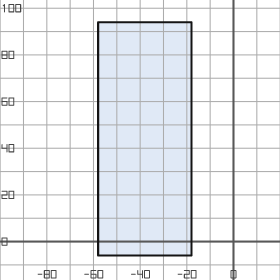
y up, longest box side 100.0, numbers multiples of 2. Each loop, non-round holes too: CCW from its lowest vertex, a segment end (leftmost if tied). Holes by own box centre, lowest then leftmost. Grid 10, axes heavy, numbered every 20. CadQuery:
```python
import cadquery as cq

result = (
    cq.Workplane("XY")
    .moveTo(-58.0, -6.0)
    .lineTo(-18.0, -6.0)
    .lineTo(-18.0, 94.0)
    .lineTo(-58.0, 94.0)
    .close()
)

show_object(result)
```